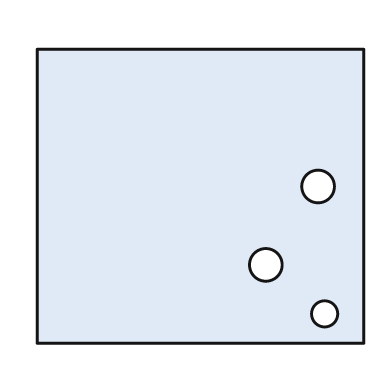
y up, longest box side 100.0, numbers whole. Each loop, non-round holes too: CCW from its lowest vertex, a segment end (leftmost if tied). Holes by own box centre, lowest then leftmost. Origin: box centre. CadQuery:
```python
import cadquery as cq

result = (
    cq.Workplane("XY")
    .moveTo(-50.0, -45.0)
    .lineTo(50.0, -45.0)
    .lineTo(50.0, 45.0)
    .lineTo(-50.0, 45.0)
    .close()
    .moveTo(38.0, -36.0)
    .circle(4.0)
    .moveTo(20.0, -21.0)
    .circle(5.0)
    .moveTo(36.0, 3.0)
    .circle(5.0)
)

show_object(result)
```